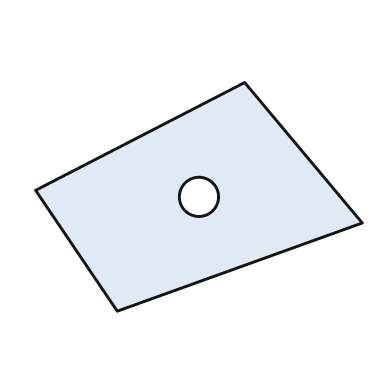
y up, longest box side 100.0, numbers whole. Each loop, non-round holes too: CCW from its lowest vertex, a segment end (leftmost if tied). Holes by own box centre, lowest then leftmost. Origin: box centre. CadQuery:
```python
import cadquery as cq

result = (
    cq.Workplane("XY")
    .moveTo(-25.0, -35.0)
    .lineTo(50.0, -8.0)
    .lineTo(14.0, 35.0)
    .lineTo(-50.0, 2.0)
    .close()
    .moveTo(0.0, 0.0)
    .circle(6.0)
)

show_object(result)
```